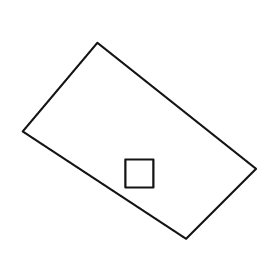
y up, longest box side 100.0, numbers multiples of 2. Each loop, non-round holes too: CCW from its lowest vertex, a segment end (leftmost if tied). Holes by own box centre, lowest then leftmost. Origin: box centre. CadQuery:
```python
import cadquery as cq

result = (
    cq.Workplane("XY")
    .moveTo(20.0, -42.0)
    .lineTo(50.0, -12.0)
    .lineTo(-18.0, 42.0)
    .lineTo(-50.0, 4.0)
    .close()
    .moveTo(-6.0, -20.0)
    .lineTo(6.0, -20.0)
    .lineTo(6.0, -8.0)
    .lineTo(-6.0, -8.0)
    .close()
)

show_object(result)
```